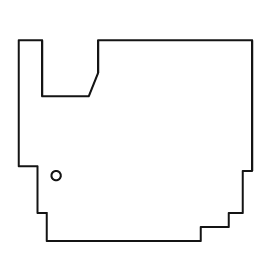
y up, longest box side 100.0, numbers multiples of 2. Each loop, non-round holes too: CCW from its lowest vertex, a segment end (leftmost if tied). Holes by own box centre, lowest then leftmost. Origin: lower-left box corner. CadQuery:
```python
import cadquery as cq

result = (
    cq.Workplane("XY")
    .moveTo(12.0, 0.0)
    .lineTo(78.0, 0.0)
    .lineTo(78.0, 6.0)
    .lineTo(90.0, 6.0)
    .lineTo(90.0, 12.0)
    .lineTo(96.0, 12.0)
    .lineTo(96.0, 30.0)
    .lineTo(100.0, 30.0)
    .lineTo(100.0, 86.0)
    .lineTo(34.0, 86.0)
    .lineTo(34.0, 72.0)
    .lineTo(30.0, 62.0)
    .lineTo(10.0, 62.0)
    .lineTo(10.0, 86.0)
    .lineTo(0.0, 86.0)
    .lineTo(0.0, 32.0)
    .lineTo(8.0, 32.0)
    .lineTo(8.0, 12.0)
    .lineTo(12.0, 12.0)
    .close()
    .moveTo(16.0, 28.0)
    .circle(2.0)
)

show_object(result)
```